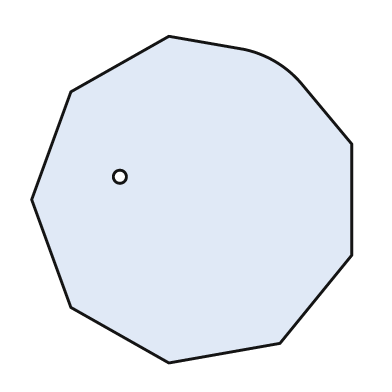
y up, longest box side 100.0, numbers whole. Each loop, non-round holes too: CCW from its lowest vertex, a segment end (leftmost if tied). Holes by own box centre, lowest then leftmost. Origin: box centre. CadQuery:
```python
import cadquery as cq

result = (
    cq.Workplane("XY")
    .moveTo(-7.0, -50.0)
    .lineTo(27.0, -44.0)
    .lineTo(49.0, -17.0)
    .lineTo(49.0, 17.0)
    .lineTo(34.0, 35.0)
    .threePointArc((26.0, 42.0), (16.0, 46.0))
    .lineTo(-7.0, 50.0)
    .lineTo(-37.0, 33.0)
    .lineTo(-49.0, 0.0)
    .lineTo(-37.0, -33.0)
    .close()
    .moveTo(-22.0, 7.0)
    .circle(2.0)
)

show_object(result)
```